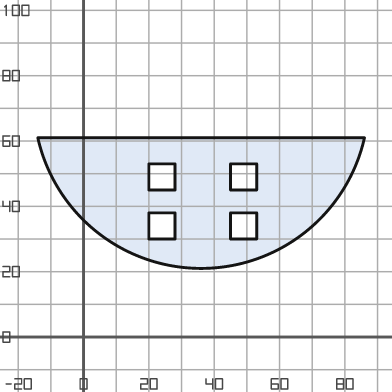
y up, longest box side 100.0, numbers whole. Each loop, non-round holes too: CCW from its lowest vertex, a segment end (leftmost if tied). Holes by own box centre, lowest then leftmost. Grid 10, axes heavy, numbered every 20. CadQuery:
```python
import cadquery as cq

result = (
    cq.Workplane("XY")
    .moveTo(-14.0, 61.0)
    .threePointArc((36.0, 21.0), (86.0, 61.0))
    .close()
    .moveTo(20.0, 30.0)
    .lineTo(28.0, 30.0)
    .lineTo(28.0, 38.0)
    .lineTo(20.0, 38.0)
    .close()
    .moveTo(45.0, 30.0)
    .lineTo(53.0, 30.0)
    .lineTo(53.0, 38.0)
    .lineTo(45.0, 38.0)
    .close()
    .moveTo(20.0, 45.0)
    .lineTo(28.0, 45.0)
    .lineTo(28.0, 53.0)
    .lineTo(20.0, 53.0)
    .close()
    .moveTo(45.0, 45.0)
    .lineTo(53.0, 45.0)
    .lineTo(53.0, 53.0)
    .lineTo(45.0, 53.0)
    .close()
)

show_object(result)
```